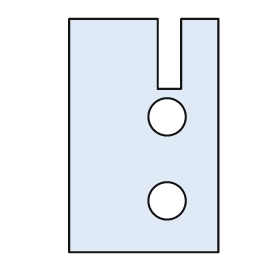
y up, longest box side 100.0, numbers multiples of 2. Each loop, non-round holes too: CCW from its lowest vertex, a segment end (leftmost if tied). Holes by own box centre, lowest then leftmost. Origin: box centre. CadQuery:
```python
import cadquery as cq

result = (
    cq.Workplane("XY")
    .moveTo(-32.0, -50.0)
    .lineTo(32.0, -50.0)
    .lineTo(32.0, 50.0)
    .lineTo(16.0, 50.0)
    .lineTo(16.0, 20.0)
    .lineTo(6.0, 20.0)
    .lineTo(6.0, 50.0)
    .lineTo(-32.0, 50.0)
    .close()
    .moveTo(10.0, -28.0)
    .circle(8.0)
    .moveTo(10.0, 8.0)
    .circle(8.0)
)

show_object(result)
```